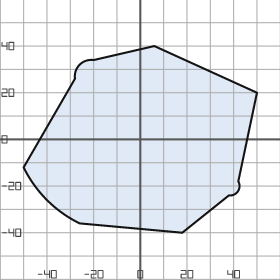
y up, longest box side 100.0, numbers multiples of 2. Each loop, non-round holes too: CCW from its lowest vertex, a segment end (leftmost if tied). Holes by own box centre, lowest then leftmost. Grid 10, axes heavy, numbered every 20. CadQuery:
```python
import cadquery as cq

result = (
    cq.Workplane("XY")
    .moveTo(18.0, -40.0)
    .lineTo(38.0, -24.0)
    .threePointArc((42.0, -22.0), (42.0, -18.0))
    .lineTo(50.0, 20.0)
    .lineTo(6.0, 40.0)
    .lineTo(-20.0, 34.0)
    .threePointArc((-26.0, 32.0), (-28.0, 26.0))
    .lineTo(-50.0, -12.0)
    .threePointArc((-40.0, -26.0), (-26.0, -36.0))
    .close()
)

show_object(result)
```